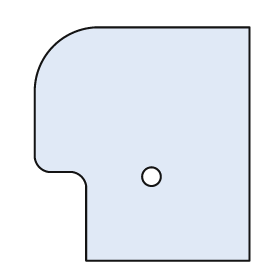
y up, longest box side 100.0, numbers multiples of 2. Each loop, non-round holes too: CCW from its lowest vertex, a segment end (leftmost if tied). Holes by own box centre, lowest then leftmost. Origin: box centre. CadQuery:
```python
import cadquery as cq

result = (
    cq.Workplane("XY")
    .moveTo(-24.0, -50.0)
    .lineTo(46.0, -50.0)
    .lineTo(46.0, 50.0)
    .lineTo(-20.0, 50.0)
    .threePointArc((-38.0, 42.0), (-46.0, 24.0))
    .lineTo(-46.0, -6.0)
    .threePointArc((-44.0, -10.0), (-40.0, -12.0))
    .lineTo(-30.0, -12.0)
    .threePointArc((-26.0, -14.0), (-24.0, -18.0))
    .close()
    .moveTo(4.0, -14.0)
    .circle(4.0)
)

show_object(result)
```